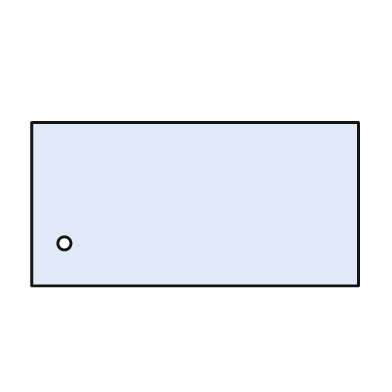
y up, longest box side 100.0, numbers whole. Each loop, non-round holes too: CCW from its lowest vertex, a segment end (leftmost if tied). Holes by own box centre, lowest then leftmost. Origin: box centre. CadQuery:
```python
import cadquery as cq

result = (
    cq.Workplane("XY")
    .moveTo(-50.0, -25.0)
    .lineTo(50.0, -25.0)
    .lineTo(50.0, 25.0)
    .lineTo(-50.0, 25.0)
    .close()
    .moveTo(-40.0, -12.0)
    .circle(2.0)
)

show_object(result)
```